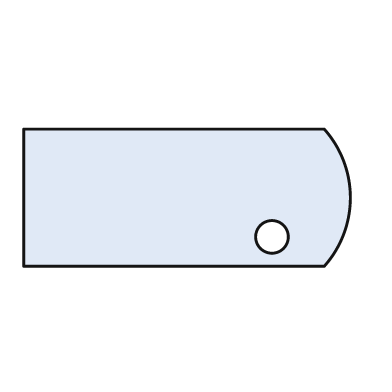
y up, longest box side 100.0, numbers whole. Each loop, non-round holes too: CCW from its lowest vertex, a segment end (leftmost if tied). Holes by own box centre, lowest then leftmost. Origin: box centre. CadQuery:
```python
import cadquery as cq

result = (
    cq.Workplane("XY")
    .moveTo(-50.0, -21.0)
    .lineTo(42.0, -21.0)
    .threePointArc((50.0, 0.0), (42.0, 21.0))
    .lineTo(-50.0, 21.0)
    .close()
    .moveTo(26.0, -12.0)
    .circle(5.0)
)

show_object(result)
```